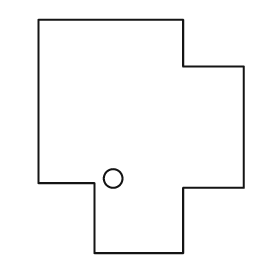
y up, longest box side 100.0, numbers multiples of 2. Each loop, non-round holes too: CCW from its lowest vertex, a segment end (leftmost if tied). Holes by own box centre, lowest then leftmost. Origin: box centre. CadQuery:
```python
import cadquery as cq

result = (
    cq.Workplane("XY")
    .moveTo(-20.0, -50.0)
    .lineTo(18.0, -50.0)
    .lineTo(18.0, -22.0)
    .lineTo(44.0, -22.0)
    .lineTo(44.0, 30.0)
    .lineTo(18.0, 30.0)
    .lineTo(18.0, 50.0)
    .lineTo(-44.0, 50.0)
    .lineTo(-44.0, -20.0)
    .lineTo(-20.0, -20.0)
    .close()
    .moveTo(-12.0, -18.0)
    .circle(4.0)
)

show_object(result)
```